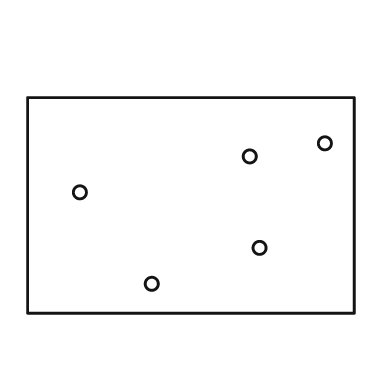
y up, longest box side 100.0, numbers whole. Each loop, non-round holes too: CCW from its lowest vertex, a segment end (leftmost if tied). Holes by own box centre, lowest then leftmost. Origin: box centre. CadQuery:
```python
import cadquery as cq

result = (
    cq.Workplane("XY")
    .moveTo(-50.0, -33.0)
    .lineTo(50.0, -33.0)
    .lineTo(50.0, 33.0)
    .lineTo(-50.0, 33.0)
    .close()
    .moveTo(-12.0, -24.0)
    .circle(2.0)
    .moveTo(21.0, -13.0)
    .circle(2.0)
    .moveTo(-34.0, 4.0)
    .circle(2.0)
    .moveTo(18.0, 15.0)
    .circle(2.0)
    .moveTo(41.0, 19.0)
    .circle(2.0)
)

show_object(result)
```